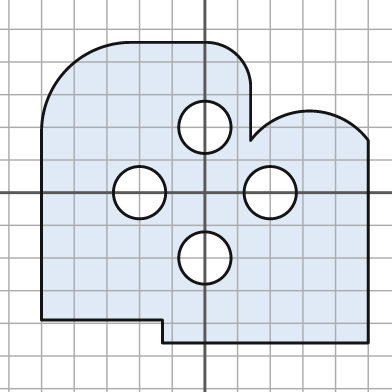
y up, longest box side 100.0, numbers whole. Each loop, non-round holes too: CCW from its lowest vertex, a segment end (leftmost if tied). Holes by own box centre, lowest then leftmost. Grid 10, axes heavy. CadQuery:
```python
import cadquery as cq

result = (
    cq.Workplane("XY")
    .moveTo(-13.0, -46.0)
    .lineTo(50.0, -46.0)
    .lineTo(50.0, 16.0)
    .threePointArc((32.0, 25.0), (14.0, 16.0))
    .lineTo(14.0, 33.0)
    .threePointArc((10.0, 42.0), (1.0, 46.0))
    .lineTo(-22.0, 46.0)
    .threePointArc((-42.0, 38.0), (-50.0, 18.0))
    .lineTo(-50.0, -39.0)
    .lineTo(-13.0, -39.0)
    .close()
    .moveTo(0.0, -20.0)
    .circle(8.0)
    .moveTo(-20.0, 0.0)
    .circle(8.0)
    .moveTo(20.0, 0.0)
    .circle(8.0)
    .moveTo(0.0, 20.0)
    .circle(8.0)
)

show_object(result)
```